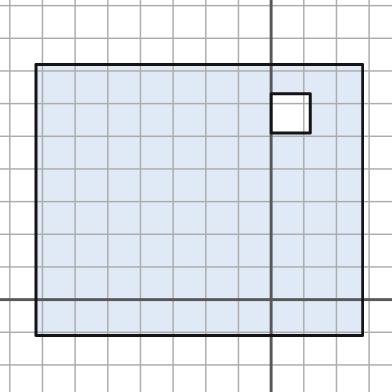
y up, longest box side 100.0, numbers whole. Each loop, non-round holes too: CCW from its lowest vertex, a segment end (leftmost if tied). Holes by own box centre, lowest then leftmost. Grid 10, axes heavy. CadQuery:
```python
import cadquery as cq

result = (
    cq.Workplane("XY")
    .moveTo(-72.0, -11.0)
    .lineTo(28.0, -11.0)
    .lineTo(28.0, 72.0)
    .lineTo(-72.0, 72.0)
    .close()
    .moveTo(0.0, 51.0)
    .lineTo(12.0, 51.0)
    .lineTo(12.0, 63.0)
    .lineTo(0.0, 63.0)
    .close()
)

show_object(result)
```